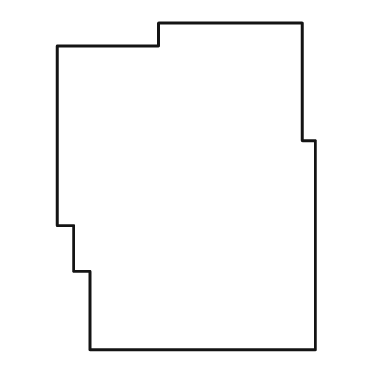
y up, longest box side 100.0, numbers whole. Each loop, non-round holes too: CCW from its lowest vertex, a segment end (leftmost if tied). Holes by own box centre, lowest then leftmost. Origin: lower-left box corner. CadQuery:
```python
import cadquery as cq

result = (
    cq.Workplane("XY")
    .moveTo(10.0, 0.0)
    .lineTo(79.0, 0.0)
    .lineTo(79.0, 64.0)
    .lineTo(75.0, 64.0)
    .lineTo(75.0, 100.0)
    .lineTo(31.0, 100.0)
    .lineTo(31.0, 93.0)
    .lineTo(0.0, 93.0)
    .lineTo(0.0, 38.0)
    .lineTo(5.0, 38.0)
    .lineTo(5.0, 24.0)
    .lineTo(10.0, 24.0)
    .close()
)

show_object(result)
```